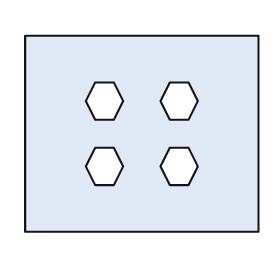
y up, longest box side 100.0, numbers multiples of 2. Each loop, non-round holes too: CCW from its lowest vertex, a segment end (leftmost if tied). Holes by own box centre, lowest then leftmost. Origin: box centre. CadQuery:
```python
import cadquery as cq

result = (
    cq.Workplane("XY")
    .moveTo(-50.0, -42.0)
    .lineTo(50.0, -42.0)
    .lineTo(50.0, 42.0)
    .lineTo(-50.0, 42.0)
    .close()
    .moveTo(-20.0, -22.0)
    .lineTo(-12.0, -22.0)
    .lineTo(-8.0, -14.0)
    .lineTo(-12.0, -6.0)
    .lineTo(-20.0, -6.0)
    .lineTo(-24.0, -14.0)
    .close()
    .moveTo(12.0, -22.0)
    .lineTo(20.0, -22.0)
    .lineTo(24.0, -14.0)
    .lineTo(20.0, -6.0)
    .lineTo(12.0, -6.0)
    .lineTo(8.0, -14.0)
    .close()
    .moveTo(-20.0, 6.0)
    .lineTo(-12.0, 6.0)
    .lineTo(-8.0, 14.0)
    .lineTo(-12.0, 22.0)
    .lineTo(-20.0, 22.0)
    .lineTo(-24.0, 14.0)
    .close()
    .moveTo(12.0, 6.0)
    .lineTo(20.0, 6.0)
    .lineTo(24.0, 14.0)
    .lineTo(20.0, 22.0)
    .lineTo(12.0, 22.0)
    .lineTo(8.0, 14.0)
    .close()
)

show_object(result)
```